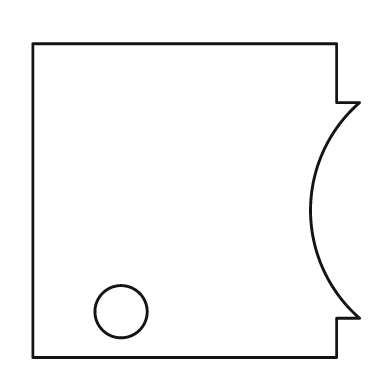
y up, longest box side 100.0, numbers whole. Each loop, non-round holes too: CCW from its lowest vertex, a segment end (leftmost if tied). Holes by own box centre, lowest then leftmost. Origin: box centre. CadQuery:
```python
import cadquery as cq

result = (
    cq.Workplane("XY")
    .moveTo(-50.0, -48.0)
    .lineTo(43.0, -48.0)
    .lineTo(43.0, -36.0)
    .lineTo(50.0, -36.0)
    .threePointArc((35.0, -3.0), (50.0, 30.0))
    .lineTo(43.0, 30.0)
    .lineTo(43.0, 48.0)
    .lineTo(-50.0, 48.0)
    .close()
    .moveTo(-23.0, -34.0)
    .circle(8.0)
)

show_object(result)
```